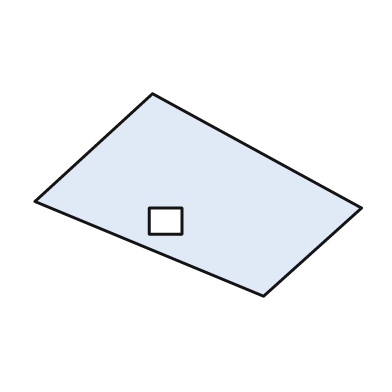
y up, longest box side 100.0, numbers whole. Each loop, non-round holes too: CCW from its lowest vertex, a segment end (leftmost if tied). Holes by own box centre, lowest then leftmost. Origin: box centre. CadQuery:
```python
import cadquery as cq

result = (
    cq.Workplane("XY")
    .moveTo(20.0, -31.0)
    .lineTo(50.0, -4.0)
    .lineTo(-14.0, 31.0)
    .lineTo(-50.0, -2.0)
    .close()
    .moveTo(-15.0, -12.0)
    .lineTo(-5.0, -12.0)
    .lineTo(-5.0, -4.0)
    .lineTo(-15.0, -4.0)
    .close()
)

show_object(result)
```